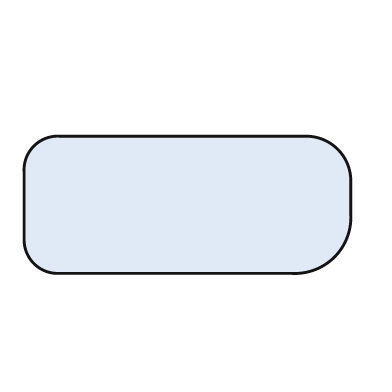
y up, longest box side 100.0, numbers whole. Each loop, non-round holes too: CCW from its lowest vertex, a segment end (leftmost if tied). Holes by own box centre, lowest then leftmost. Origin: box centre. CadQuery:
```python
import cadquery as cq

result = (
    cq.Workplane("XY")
    .moveTo(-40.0, -21.0)
    .lineTo(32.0, -21.0)
    .threePointArc((45.0, -16.0), (50.0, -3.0))
    .lineTo(50.0, 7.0)
    .threePointArc((46.0, 17.0), (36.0, 21.0))
    .lineTo(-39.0, 21.0)
    .threePointArc((-47.0, 18.0), (-50.0, 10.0))
    .lineTo(-50.0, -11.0)
    .threePointArc((-47.0, -18.0), (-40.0, -21.0))
    .close()
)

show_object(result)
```